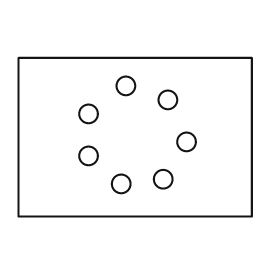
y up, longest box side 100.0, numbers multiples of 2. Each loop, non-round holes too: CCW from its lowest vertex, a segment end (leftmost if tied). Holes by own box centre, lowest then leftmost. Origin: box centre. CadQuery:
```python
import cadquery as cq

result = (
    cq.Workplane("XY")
    .moveTo(-50.0, -34.0)
    .lineTo(50.0, -34.0)
    .lineTo(50.0, 34.0)
    .lineTo(-50.0, 34.0)
    .close()
    .moveTo(-6.0, -20.0)
    .circle(4.0)
    .moveTo(12.0, -18.0)
    .circle(4.0)
    .moveTo(-20.0, -8.0)
    .circle(4.0)
    .moveTo(22.0, -2.0)
    .circle(4.0)
    .moveTo(-20.0, 10.0)
    .circle(4.0)
    .moveTo(14.0, 16.0)
    .circle(4.0)
    .moveTo(-4.0, 22.0)
    .circle(4.0)
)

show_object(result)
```